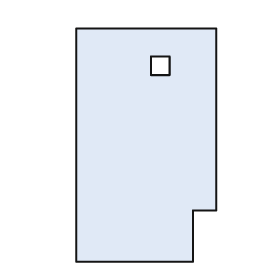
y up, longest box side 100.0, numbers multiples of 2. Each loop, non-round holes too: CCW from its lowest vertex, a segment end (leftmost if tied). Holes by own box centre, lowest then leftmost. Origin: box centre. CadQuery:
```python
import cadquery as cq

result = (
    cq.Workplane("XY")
    .moveTo(-30.0, -50.0)
    .lineTo(20.0, -50.0)
    .lineTo(20.0, -28.0)
    .lineTo(30.0, -28.0)
    .lineTo(30.0, 50.0)
    .lineTo(-30.0, 50.0)
    .close()
    .moveTo(2.0, 30.0)
    .lineTo(10.0, 30.0)
    .lineTo(10.0, 38.0)
    .lineTo(2.0, 38.0)
    .close()
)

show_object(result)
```